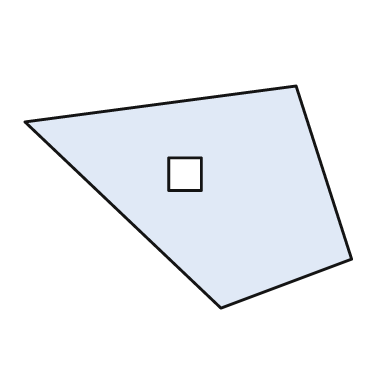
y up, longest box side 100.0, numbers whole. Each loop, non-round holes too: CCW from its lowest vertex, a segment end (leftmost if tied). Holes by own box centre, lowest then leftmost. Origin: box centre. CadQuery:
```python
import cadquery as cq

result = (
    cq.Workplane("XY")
    .moveTo(10.0, -34.0)
    .lineTo(50.0, -19.0)
    .lineTo(33.0, 34.0)
    .lineTo(-50.0, 23.0)
    .close()
    .moveTo(-6.0, 2.0)
    .lineTo(4.0, 2.0)
    .lineTo(4.0, 12.0)
    .lineTo(-6.0, 12.0)
    .close()
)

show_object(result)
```